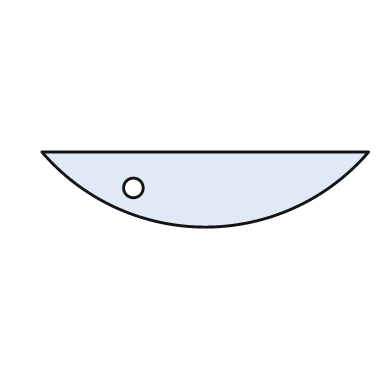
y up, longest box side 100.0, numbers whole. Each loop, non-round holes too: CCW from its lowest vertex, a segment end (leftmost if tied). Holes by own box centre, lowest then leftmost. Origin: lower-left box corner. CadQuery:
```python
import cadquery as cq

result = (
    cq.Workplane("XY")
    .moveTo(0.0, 23.0)
    .threePointArc((50.0, 0.0), (100.0, 23.0))
    .close()
    .moveTo(28.0, 12.0)
    .circle(3.0)
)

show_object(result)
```